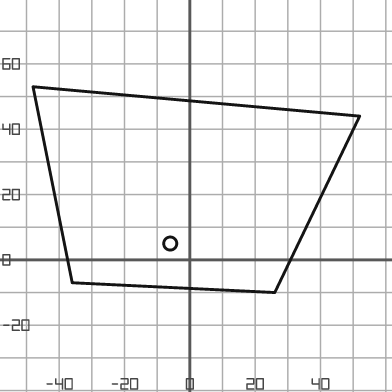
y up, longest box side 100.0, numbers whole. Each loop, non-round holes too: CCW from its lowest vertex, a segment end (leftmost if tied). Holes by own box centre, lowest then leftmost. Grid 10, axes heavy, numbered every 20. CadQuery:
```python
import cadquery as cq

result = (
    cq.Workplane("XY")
    .moveTo(26.0, -10.0)
    .lineTo(52.0, 44.0)
    .lineTo(-48.0, 53.0)
    .lineTo(-36.0, -7.0)
    .close()
    .moveTo(-6.0, 5.0)
    .circle(2.0)
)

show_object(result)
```